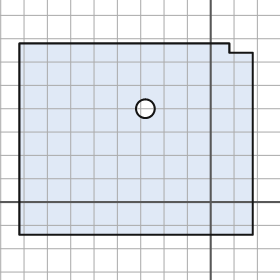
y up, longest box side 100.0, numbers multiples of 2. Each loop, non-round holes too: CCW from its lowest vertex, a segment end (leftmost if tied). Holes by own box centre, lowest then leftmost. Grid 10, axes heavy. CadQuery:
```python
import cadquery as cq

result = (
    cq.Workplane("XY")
    .moveTo(-82.0, -14.0)
    .lineTo(18.0, -14.0)
    .lineTo(18.0, 64.0)
    .lineTo(8.0, 64.0)
    .lineTo(8.0, 68.0)
    .lineTo(-82.0, 68.0)
    .close()
    .moveTo(-28.0, 40.0)
    .circle(4.0)
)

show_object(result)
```